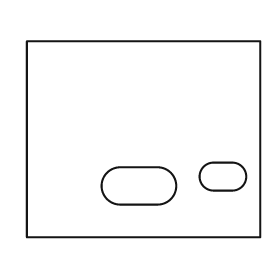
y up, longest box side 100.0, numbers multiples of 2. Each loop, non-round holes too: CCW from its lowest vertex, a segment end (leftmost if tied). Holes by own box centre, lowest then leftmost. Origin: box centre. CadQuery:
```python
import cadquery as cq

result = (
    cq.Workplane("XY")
    .moveTo(-50.0, -42.0)
    .lineTo(50.0, -42.0)
    .lineTo(50.0, 42.0)
    .lineTo(-50.0, 42.0)
    .close()
    .moveTo(-10.0, -28.0)
    .lineTo(6.0, -28.0)
    .threePointArc((14.0, -20.0), (6.0, -12.0))
    .lineTo(-10.0, -12.0)
    .threePointArc((-18.0, -20.0), (-10.0, -28.0))
    .close()
    .moveTo(30.0, -22.0)
    .lineTo(38.0, -22.0)
    .threePointArc((44.0, -16.0), (38.0, -10.0))
    .lineTo(30.0, -10.0)
    .threePointArc((24.0, -16.0), (30.0, -22.0))
    .close()
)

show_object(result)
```